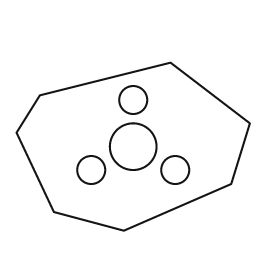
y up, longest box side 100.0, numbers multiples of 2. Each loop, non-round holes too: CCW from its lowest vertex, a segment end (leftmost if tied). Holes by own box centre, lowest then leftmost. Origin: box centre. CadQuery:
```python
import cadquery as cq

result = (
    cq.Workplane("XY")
    .moveTo(-4.0, -36.0)
    .lineTo(42.0, -16.0)
    .lineTo(50.0, 10.0)
    .lineTo(16.0, 36.0)
    .lineTo(-40.0, 22.0)
    .lineTo(-50.0, 6.0)
    .lineTo(-34.0, -28.0)
    .close()
    .moveTo(-18.0, -10.0)
    .circle(6.0)
    .moveTo(18.0, -10.0)
    .circle(6.0)
    .moveTo(0.0, 0.0)
    .circle(10.0)
    .moveTo(0.0, 20.0)
    .circle(6.0)
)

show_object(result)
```